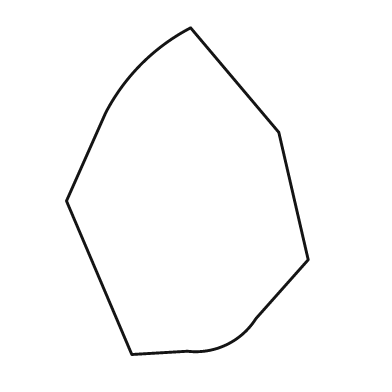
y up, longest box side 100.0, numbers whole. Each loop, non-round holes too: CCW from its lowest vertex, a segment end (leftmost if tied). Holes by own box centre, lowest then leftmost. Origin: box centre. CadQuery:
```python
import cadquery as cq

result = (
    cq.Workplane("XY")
    .moveTo(-17.0, -50.0)
    .lineTo(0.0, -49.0)
    .threePointArc((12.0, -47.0), (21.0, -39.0))
    .lineTo(37.0, -21.0)
    .lineTo(28.0, 18.0)
    .lineTo(1.0, 50.0)
    .threePointArc((-14.0, 39.0), (-25.0, 24.0))
    .lineTo(-37.0, -3.0)
    .close()
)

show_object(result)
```